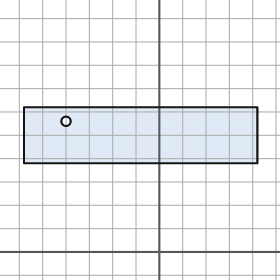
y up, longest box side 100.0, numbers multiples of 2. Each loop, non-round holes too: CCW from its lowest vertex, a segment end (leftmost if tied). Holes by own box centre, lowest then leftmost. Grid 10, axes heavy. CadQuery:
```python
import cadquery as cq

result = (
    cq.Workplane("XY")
    .moveTo(-58.0, 38.0)
    .lineTo(42.0, 38.0)
    .lineTo(42.0, 62.0)
    .lineTo(-58.0, 62.0)
    .close()
    .moveTo(-40.0, 56.0)
    .circle(2.0)
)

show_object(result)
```